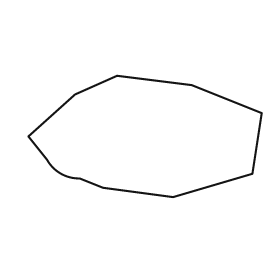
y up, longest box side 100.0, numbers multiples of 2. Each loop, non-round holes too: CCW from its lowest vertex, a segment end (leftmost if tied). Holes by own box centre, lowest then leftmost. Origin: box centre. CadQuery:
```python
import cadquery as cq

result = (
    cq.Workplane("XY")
    .moveTo(12.0, -26.0)
    .lineTo(46.0, -16.0)
    .lineTo(50.0, 10.0)
    .lineTo(20.0, 22.0)
    .lineTo(-12.0, 26.0)
    .lineTo(-30.0, 18.0)
    .lineTo(-50.0, 0.0)
    .lineTo(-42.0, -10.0)
    .threePointArc((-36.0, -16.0), (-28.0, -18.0))
    .lineTo(-18.0, -22.0)
    .close()
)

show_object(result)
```